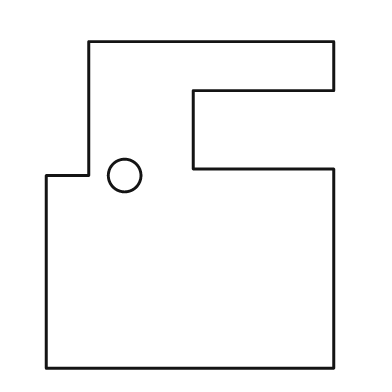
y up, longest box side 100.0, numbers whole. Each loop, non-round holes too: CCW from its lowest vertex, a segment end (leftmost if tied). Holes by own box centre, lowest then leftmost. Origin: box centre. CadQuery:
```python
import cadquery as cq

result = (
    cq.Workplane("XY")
    .moveTo(-44.0, -50.0)
    .lineTo(44.0, -50.0)
    .lineTo(44.0, 11.0)
    .lineTo(1.0, 11.0)
    .lineTo(1.0, 35.0)
    .lineTo(44.0, 35.0)
    .lineTo(44.0, 50.0)
    .lineTo(-31.0, 50.0)
    .lineTo(-31.0, 9.0)
    .lineTo(-44.0, 9.0)
    .close()
    .moveTo(-20.0, 9.0)
    .circle(5.0)
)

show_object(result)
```